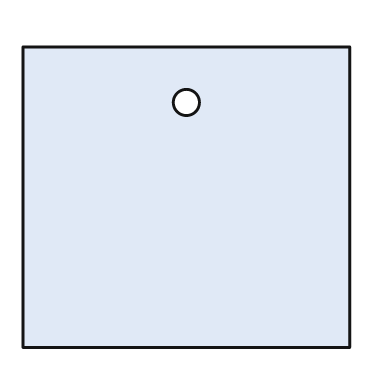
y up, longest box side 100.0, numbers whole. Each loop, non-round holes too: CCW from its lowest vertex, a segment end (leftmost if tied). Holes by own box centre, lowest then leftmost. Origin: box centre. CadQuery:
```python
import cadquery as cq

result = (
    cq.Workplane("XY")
    .moveTo(-50.0, -46.0)
    .lineTo(50.0, -46.0)
    .lineTo(50.0, 46.0)
    .lineTo(-50.0, 46.0)
    .close()
    .moveTo(0.0, 29.0)
    .circle(4.0)
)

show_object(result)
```